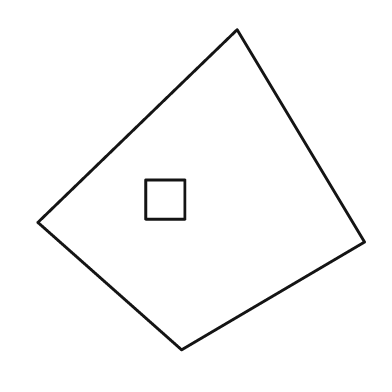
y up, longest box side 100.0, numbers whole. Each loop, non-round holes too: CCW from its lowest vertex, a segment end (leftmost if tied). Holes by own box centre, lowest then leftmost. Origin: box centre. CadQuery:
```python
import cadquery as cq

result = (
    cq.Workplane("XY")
    .moveTo(-6.0, -49.0)
    .lineTo(50.0, -16.0)
    .lineTo(11.0, 49.0)
    .lineTo(-50.0, -10.0)
    .close()
    .moveTo(-17.0, -9.0)
    .lineTo(-5.0, -9.0)
    .lineTo(-5.0, 3.0)
    .lineTo(-17.0, 3.0)
    .close()
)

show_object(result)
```